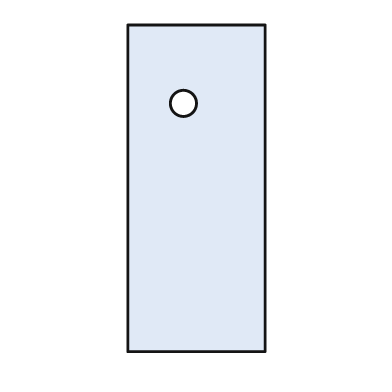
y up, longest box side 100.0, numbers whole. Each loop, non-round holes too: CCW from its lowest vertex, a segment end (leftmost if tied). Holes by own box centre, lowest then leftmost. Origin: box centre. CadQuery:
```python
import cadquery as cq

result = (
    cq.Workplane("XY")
    .moveTo(-21.0, -50.0)
    .lineTo(21.0, -50.0)
    .lineTo(21.0, 50.0)
    .lineTo(-21.0, 50.0)
    .close()
    .moveTo(-4.0, 26.0)
    .circle(4.0)
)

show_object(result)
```